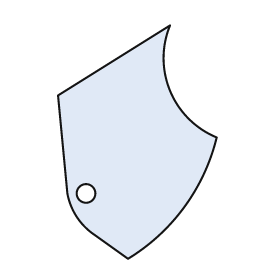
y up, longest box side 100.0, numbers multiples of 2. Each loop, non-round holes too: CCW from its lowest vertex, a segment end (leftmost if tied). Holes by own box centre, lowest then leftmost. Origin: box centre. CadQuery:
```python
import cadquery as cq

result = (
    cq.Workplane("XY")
    .moveTo(-4.0, -50.0)
    .threePointArc((20.0, -28.0), (34.0, 2.0))
    .threePointArc((14.0, 22.0), (14.0, 50.0))
    .lineTo(-34.0, 20.0)
    .lineTo(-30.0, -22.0)
    .threePointArc((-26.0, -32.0), (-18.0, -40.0))
    .close()
    .moveTo(-22.0, -22.0)
    .circle(4.0)
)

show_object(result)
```